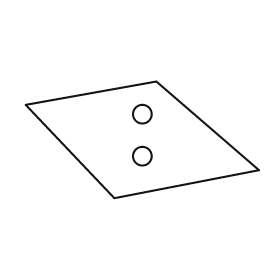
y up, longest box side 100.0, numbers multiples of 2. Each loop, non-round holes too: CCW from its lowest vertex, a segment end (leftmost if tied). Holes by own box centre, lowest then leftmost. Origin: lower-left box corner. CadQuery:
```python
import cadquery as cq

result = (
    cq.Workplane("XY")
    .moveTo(38.0, 0.0)
    .lineTo(100.0, 12.0)
    .lineTo(56.0, 50.0)
    .lineTo(0.0, 40.0)
    .close()
    .moveTo(50.0, 18.0)
    .circle(4.0)
    .moveTo(50.0, 36.0)
    .circle(4.0)
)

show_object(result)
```